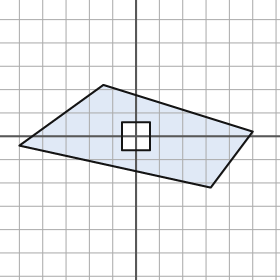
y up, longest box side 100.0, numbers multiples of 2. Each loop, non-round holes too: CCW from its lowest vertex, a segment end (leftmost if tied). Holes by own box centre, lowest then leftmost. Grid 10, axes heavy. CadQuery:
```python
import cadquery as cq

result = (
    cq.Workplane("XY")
    .moveTo(32.0, -22.0)
    .lineTo(50.0, 2.0)
    .lineTo(-14.0, 22.0)
    .lineTo(-50.0, -4.0)
    .close()
    .moveTo(-6.0, -6.0)
    .lineTo(6.0, -6.0)
    .lineTo(6.0, 6.0)
    .lineTo(-6.0, 6.0)
    .close()
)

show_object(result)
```